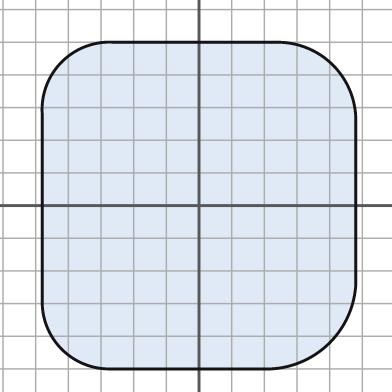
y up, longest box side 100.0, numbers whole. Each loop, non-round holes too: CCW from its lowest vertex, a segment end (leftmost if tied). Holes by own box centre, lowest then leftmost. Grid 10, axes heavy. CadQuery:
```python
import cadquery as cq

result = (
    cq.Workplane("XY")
    .moveTo(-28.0, -50.0)
    .lineTo(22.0, -50.0)
    .threePointArc((40.0, -42.0), (48.0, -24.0))
    .lineTo(48.0, 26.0)
    .threePointArc((41.0, 43.0), (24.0, 50.0))
    .lineTo(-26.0, 50.0)
    .threePointArc((-42.0, 44.0), (-48.0, 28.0))
    .lineTo(-48.0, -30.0)
    .threePointArc((-42.0, -44.0), (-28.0, -50.0))
    .close()
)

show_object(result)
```